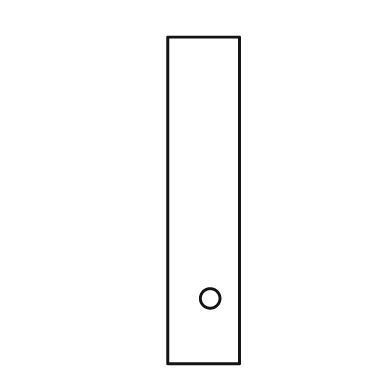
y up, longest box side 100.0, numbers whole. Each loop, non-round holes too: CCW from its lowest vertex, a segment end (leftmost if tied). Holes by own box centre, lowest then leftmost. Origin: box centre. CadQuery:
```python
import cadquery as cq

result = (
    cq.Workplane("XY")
    .moveTo(-11.0, -50.0)
    .lineTo(11.0, -50.0)
    .lineTo(11.0, 50.0)
    .lineTo(-11.0, 50.0)
    .close()
    .moveTo(2.0, -30.0)
    .circle(3.0)
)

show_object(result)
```